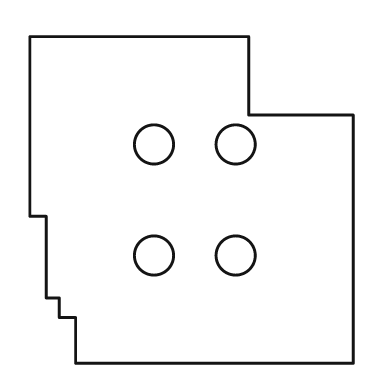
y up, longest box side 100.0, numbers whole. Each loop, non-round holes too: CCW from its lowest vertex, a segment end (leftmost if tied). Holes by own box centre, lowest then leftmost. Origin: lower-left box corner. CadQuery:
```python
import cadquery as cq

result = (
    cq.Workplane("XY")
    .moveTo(14.0, 0.0)
    .lineTo(99.0, 0.0)
    .lineTo(99.0, 76.0)
    .lineTo(67.0, 76.0)
    .lineTo(67.0, 100.0)
    .lineTo(0.0, 100.0)
    .lineTo(0.0, 45.0)
    .lineTo(5.0, 45.0)
    .lineTo(5.0, 20.0)
    .lineTo(9.0, 20.0)
    .lineTo(9.0, 14.0)
    .lineTo(14.0, 14.0)
    .close()
    .moveTo(38.0, 33.0)
    .circle(6.0)
    .moveTo(63.0, 33.0)
    .circle(6.0)
    .moveTo(38.0, 67.0)
    .circle(6.0)
    .moveTo(63.0, 67.0)
    .circle(6.0)
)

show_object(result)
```